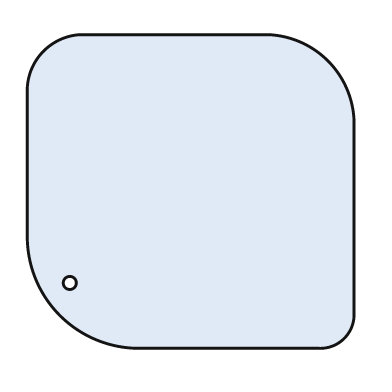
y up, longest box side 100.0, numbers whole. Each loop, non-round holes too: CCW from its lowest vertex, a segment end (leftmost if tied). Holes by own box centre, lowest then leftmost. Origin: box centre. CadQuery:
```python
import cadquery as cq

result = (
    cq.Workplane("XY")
    .moveTo(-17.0, -48.0)
    .lineTo(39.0, -48.0)
    .threePointArc((47.0, -45.0), (50.0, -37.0))
    .lineTo(50.0, 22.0)
    .threePointArc((42.0, 40.0), (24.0, 48.0))
    .lineTo(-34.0, 48.0)
    .threePointArc((-45.0, 43.0), (-50.0, 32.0))
    .lineTo(-50.0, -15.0)
    .threePointArc((-40.0, -38.0), (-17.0, -48.0))
    .close()
    .moveTo(-37.0, -28.0)
    .circle(2.0)
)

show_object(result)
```